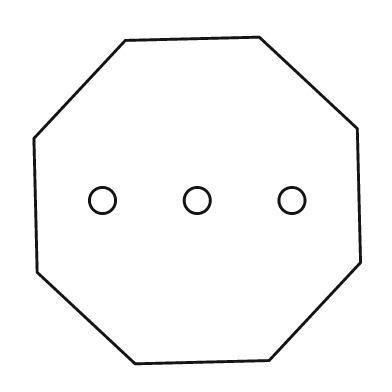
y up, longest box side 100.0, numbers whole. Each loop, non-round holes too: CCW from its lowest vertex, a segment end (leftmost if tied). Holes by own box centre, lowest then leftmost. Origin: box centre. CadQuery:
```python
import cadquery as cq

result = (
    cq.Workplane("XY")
    .moveTo(-19.0, -50.0)
    .lineTo(22.0, -49.0)
    .lineTo(50.0, -19.0)
    .lineTo(49.0, 22.0)
    .lineTo(19.0, 50.0)
    .lineTo(-22.0, 49.0)
    .lineTo(-50.0, 19.0)
    .lineTo(-49.0, -22.0)
    .close()
    .moveTo(-29.0, 0.0)
    .circle(4.0)
    .moveTo(0.0, 0.0)
    .circle(4.0)
    .moveTo(29.0, 0.0)
    .circle(4.0)
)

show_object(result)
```